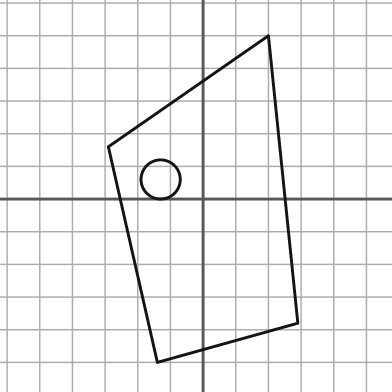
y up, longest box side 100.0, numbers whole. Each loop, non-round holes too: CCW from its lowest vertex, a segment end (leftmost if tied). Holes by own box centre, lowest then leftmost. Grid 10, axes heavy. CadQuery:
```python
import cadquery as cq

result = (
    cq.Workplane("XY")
    .moveTo(-14.0, -50.0)
    .lineTo(29.0, -38.0)
    .lineTo(20.0, 50.0)
    .lineTo(-29.0, 16.0)
    .close()
    .moveTo(-13.0, 6.0)
    .circle(6.0)
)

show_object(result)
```